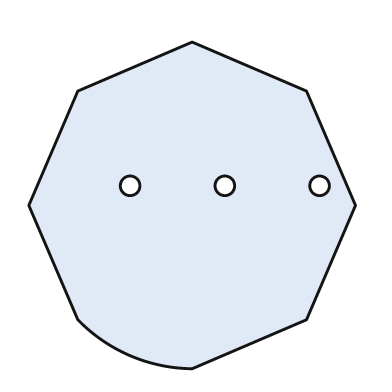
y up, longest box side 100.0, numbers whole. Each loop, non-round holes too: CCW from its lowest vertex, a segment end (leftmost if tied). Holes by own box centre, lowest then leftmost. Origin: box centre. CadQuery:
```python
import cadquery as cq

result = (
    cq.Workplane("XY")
    .moveTo(0.0, -50.0)
    .lineTo(35.0, -35.0)
    .lineTo(50.0, 0.0)
    .lineTo(35.0, 35.0)
    .lineTo(0.0, 50.0)
    .lineTo(-35.0, 35.0)
    .lineTo(-50.0, 0.0)
    .lineTo(-35.0, -35.0)
    .threePointArc((-19.0, -46.0), (0.0, -50.0))
    .close()
    .moveTo(-19.0, 6.0)
    .circle(3.0)
    .moveTo(10.0, 6.0)
    .circle(3.0)
    .moveTo(39.0, 6.0)
    .circle(3.0)
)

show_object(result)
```